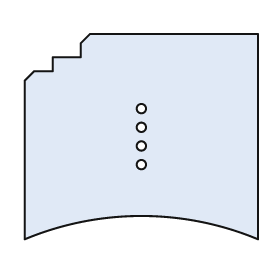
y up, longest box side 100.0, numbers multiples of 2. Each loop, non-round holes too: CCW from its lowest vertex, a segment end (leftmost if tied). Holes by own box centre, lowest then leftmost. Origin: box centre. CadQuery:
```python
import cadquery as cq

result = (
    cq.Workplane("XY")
    .moveTo(-50.0, -44.0)
    .threePointArc((0.0, -34.0), (50.0, -44.0))
    .lineTo(50.0, 44.0)
    .lineTo(-22.0, 44.0)
    .lineTo(-26.0, 40.0)
    .lineTo(-26.0, 34.0)
    .lineTo(-38.0, 34.0)
    .lineTo(-38.0, 28.0)
    .lineTo(-46.0, 28.0)
    .lineTo(-50.0, 24.0)
    .close()
    .moveTo(0.0, -12.0)
    .circle(2.0)
    .moveTo(0.0, -4.0)
    .circle(2.0)
    .moveTo(0.0, 4.0)
    .circle(2.0)
    .moveTo(0.0, 12.0)
    .circle(2.0)
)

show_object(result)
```